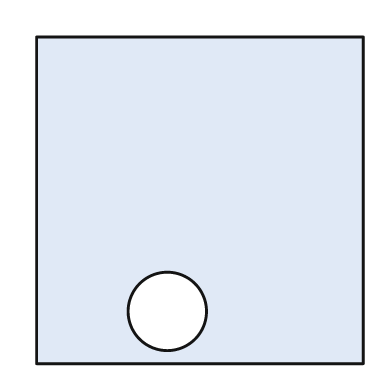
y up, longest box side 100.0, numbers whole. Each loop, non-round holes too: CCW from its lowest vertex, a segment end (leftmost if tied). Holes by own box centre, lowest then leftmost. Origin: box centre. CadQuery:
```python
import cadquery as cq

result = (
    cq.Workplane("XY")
    .moveTo(-50.0, -50.0)
    .lineTo(50.0, -50.0)
    .lineTo(50.0, 50.0)
    .lineTo(-50.0, 50.0)
    .close()
    .moveTo(-10.0, -34.0)
    .circle(12.0)
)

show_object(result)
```